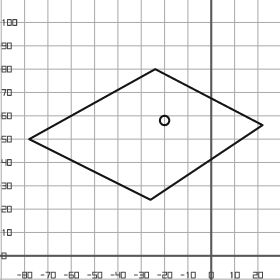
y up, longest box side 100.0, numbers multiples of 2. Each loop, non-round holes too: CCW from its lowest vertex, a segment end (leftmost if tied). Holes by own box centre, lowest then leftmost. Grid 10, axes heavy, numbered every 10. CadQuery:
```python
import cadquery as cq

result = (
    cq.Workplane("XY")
    .moveTo(-26.0, 24.0)
    .lineTo(22.0, 56.0)
    .lineTo(-24.0, 80.0)
    .lineTo(-78.0, 50.0)
    .close()
    .moveTo(-20.0, 58.0)
    .circle(2.0)
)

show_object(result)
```